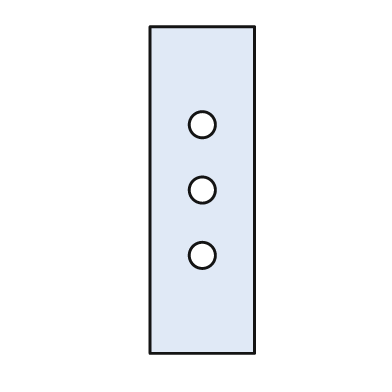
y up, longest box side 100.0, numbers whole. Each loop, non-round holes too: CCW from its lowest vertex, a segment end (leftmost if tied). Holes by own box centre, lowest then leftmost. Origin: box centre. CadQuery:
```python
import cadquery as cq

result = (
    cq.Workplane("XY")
    .moveTo(-16.0, -50.0)
    .lineTo(16.0, -50.0)
    .lineTo(16.0, 50.0)
    .lineTo(-16.0, 50.0)
    .close()
    .moveTo(0.0, -20.0)
    .circle(4.0)
    .moveTo(0.0, 0.0)
    .circle(4.0)
    .moveTo(0.0, 20.0)
    .circle(4.0)
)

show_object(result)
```